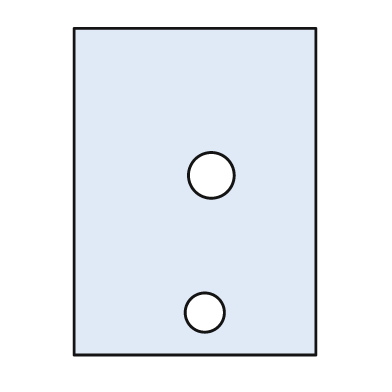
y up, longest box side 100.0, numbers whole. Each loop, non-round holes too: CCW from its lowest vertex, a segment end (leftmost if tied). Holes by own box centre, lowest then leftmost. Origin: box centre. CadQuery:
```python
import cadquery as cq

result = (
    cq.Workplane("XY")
    .moveTo(-37.0, -50.0)
    .lineTo(37.0, -50.0)
    .lineTo(37.0, 50.0)
    .lineTo(-37.0, 50.0)
    .close()
    .moveTo(3.0, -37.0)
    .circle(6.0)
    .moveTo(5.0, 5.0)
    .circle(7.0)
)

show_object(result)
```